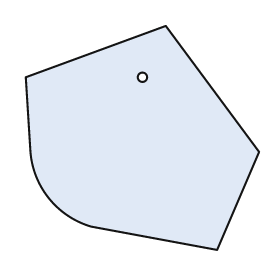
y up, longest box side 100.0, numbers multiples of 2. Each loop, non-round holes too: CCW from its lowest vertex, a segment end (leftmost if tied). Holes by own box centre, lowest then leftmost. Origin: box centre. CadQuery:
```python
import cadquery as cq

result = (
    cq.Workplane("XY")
    .moveTo(32.0, -48.0)
    .lineTo(50.0, -6.0)
    .lineTo(10.0, 48.0)
    .lineTo(-50.0, 26.0)
    .lineTo(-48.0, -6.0)
    .threePointArc((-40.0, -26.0), (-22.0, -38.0))
    .close()
    .moveTo(0.0, 26.0)
    .circle(2.0)
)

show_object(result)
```